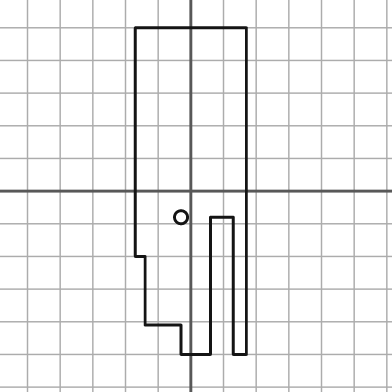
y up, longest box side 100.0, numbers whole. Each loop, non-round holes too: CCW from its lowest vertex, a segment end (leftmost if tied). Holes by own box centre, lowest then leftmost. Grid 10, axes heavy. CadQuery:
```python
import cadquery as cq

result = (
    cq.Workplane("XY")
    .moveTo(-3.0, -50.0)
    .lineTo(6.0, -50.0)
    .lineTo(6.0, -8.0)
    .lineTo(13.0, -8.0)
    .lineTo(13.0, -50.0)
    .lineTo(17.0, -50.0)
    .lineTo(17.0, 50.0)
    .lineTo(-17.0, 50.0)
    .lineTo(-17.0, -20.0)
    .lineTo(-14.0, -20.0)
    .lineTo(-14.0, -41.0)
    .lineTo(-3.0, -41.0)
    .close()
    .moveTo(-3.0, -8.0)
    .circle(2.0)
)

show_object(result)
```